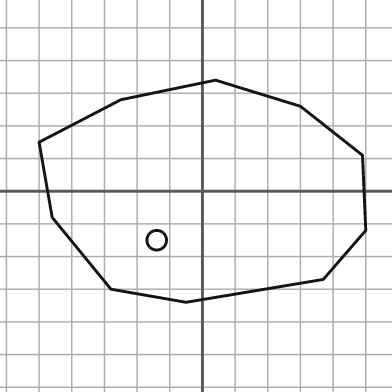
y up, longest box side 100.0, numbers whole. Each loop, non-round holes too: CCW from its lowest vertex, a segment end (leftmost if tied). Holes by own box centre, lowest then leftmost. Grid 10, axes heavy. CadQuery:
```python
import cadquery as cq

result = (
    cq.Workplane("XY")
    .moveTo(-5.0, -34.0)
    .lineTo(37.0, -27.0)
    .lineTo(50.0, -12.0)
    .lineTo(49.0, 11.0)
    .lineTo(30.0, 26.0)
    .lineTo(4.0, 34.0)
    .lineTo(-25.0, 28.0)
    .lineTo(-50.0, 15.0)
    .lineTo(-46.0, -8.0)
    .lineTo(-28.0, -30.0)
    .close()
    .moveTo(-14.0, -15.0)
    .circle(3.0)
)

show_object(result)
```